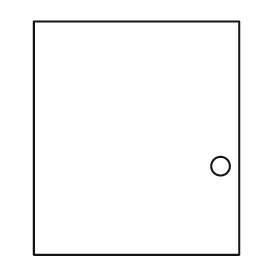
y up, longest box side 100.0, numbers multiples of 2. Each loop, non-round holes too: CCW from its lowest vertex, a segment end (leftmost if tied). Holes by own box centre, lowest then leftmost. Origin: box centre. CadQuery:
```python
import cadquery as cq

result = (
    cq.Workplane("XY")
    .moveTo(-44.0, -50.0)
    .lineTo(44.0, -50.0)
    .lineTo(44.0, 50.0)
    .lineTo(-44.0, 50.0)
    .close()
    .moveTo(36.0, -12.0)
    .circle(4.0)
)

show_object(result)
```